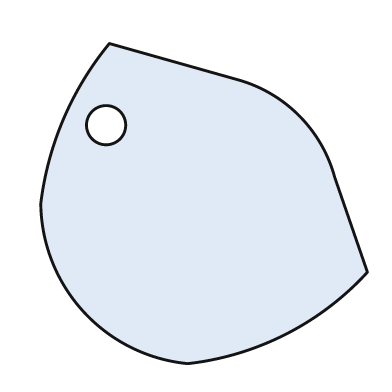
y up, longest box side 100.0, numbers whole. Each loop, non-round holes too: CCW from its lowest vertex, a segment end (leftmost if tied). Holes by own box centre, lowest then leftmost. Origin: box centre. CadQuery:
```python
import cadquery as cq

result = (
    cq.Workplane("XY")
    .moveTo(-5.0, -49.0)
    .threePointArc((25.0, -40.0), (50.0, -21.0))
    .lineTo(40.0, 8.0)
    .threePointArc((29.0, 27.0), (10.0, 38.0))
    .lineTo(-29.0, 49.0)
    .threePointArc((-43.0, 26.0), (-50.0, 0.0))
    .threePointArc((-37.0, -33.0), (-5.0, -49.0))
    .close()
    .moveTo(-30.0, 24.0)
    .circle(6.0)
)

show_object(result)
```